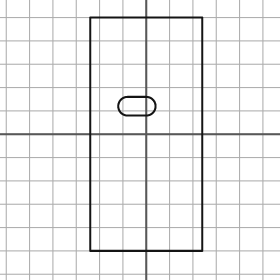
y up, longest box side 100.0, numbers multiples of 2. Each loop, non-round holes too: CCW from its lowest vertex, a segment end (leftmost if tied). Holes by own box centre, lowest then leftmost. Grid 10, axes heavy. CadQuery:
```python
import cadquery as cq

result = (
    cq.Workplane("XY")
    .moveTo(-24.0, -50.0)
    .lineTo(24.0, -50.0)
    .lineTo(24.0, 50.0)
    .lineTo(-24.0, 50.0)
    .close()
    .moveTo(-8.0, 8.0)
    .lineTo(0.0, 8.0)
    .threePointArc((4.0, 12.0), (0.0, 16.0))
    .lineTo(-8.0, 16.0)
    .threePointArc((-12.0, 12.0), (-8.0, 8.0))
    .close()
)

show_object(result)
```